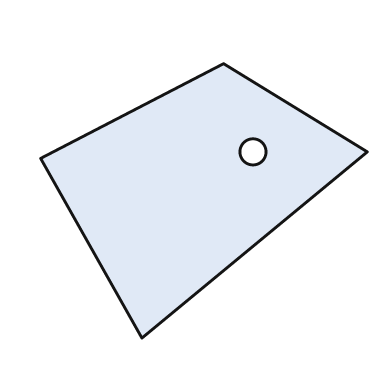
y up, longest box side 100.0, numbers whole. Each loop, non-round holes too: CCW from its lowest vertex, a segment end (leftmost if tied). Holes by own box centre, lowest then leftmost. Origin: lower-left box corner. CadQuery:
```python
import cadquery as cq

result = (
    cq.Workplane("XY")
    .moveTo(31.0, 0.0)
    .lineTo(100.0, 57.0)
    .lineTo(56.0, 84.0)
    .lineTo(0.0, 55.0)
    .close()
    .moveTo(65.0, 57.0)
    .circle(4.0)
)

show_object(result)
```